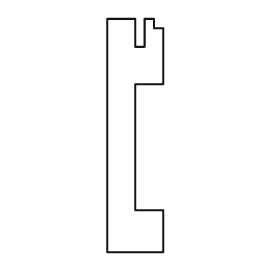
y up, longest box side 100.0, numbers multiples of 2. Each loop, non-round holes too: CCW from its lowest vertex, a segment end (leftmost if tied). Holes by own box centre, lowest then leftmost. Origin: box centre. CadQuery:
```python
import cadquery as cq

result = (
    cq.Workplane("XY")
    .moveTo(-12.0, -50.0)
    .lineTo(12.0, -50.0)
    .lineTo(12.0, -32.0)
    .lineTo(0.0, -32.0)
    .lineTo(0.0, 22.0)
    .lineTo(12.0, 22.0)
    .lineTo(12.0, 46.0)
    .lineTo(8.0, 46.0)
    .lineTo(8.0, 50.0)
    .lineTo(4.0, 50.0)
    .lineTo(4.0, 38.0)
    .lineTo(0.0, 38.0)
    .lineTo(0.0, 50.0)
    .lineTo(-12.0, 50.0)
    .close()
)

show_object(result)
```